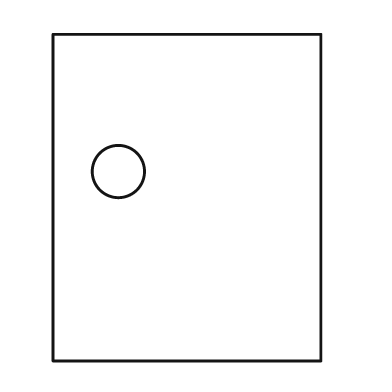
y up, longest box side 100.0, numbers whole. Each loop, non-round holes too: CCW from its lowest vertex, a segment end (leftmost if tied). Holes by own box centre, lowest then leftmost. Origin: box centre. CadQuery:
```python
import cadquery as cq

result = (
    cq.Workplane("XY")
    .moveTo(-41.0, -50.0)
    .lineTo(41.0, -50.0)
    .lineTo(41.0, 50.0)
    .lineTo(-41.0, 50.0)
    .close()
    .moveTo(-21.0, 8.0)
    .circle(8.0)
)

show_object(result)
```